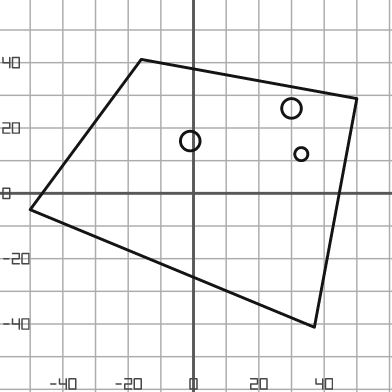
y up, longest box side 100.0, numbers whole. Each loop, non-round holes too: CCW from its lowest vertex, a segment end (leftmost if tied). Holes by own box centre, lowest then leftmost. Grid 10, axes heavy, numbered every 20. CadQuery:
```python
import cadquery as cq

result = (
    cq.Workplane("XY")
    .moveTo(37.0, -41.0)
    .lineTo(50.0, 29.0)
    .lineTo(-16.0, 41.0)
    .lineTo(-50.0, -5.0)
    .close()
    .moveTo(33.0, 12.0)
    .circle(2.0)
    .moveTo(-1.0, 16.0)
    .circle(3.0)
    .moveTo(30.0, 26.0)
    .circle(3.0)
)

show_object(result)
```